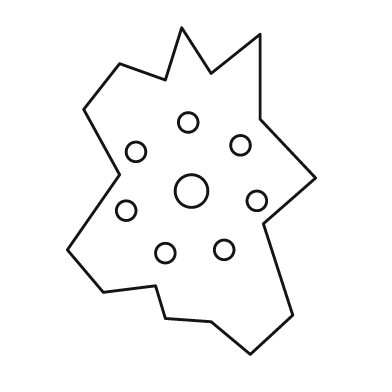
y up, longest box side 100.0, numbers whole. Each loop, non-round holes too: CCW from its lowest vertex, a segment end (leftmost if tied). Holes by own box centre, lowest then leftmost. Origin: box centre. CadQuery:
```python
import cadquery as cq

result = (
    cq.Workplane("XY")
    .moveTo(18.0, -50.0)
    .lineTo(31.0, -38.0)
    .lineTo(22.0, -10.0)
    .lineTo(38.0, 4.0)
    .lineTo(21.0, 22.0)
    .lineTo(21.0, 48.0)
    .lineTo(6.0, 36.0)
    .lineTo(-3.0, 50.0)
    .lineTo(-8.0, 34.0)
    .lineTo(-22.0, 39.0)
    .lineTo(-33.0, 25.0)
    .lineTo(-22.0, 5.0)
    .lineTo(-38.0, -18.0)
    .lineTo(-27.0, -31.0)
    .lineTo(-11.0, -29.0)
    .lineTo(-8.0, -39.0)
    .lineTo(6.0, -40.0)
    .close()
    .moveTo(-8.0, -19.0)
    .circle(3.0)
    .moveTo(10.0, -18.0)
    .circle(3.0)
    .moveTo(-20.0, -6.0)
    .circle(3.0)
    .moveTo(20.0, -3.0)
    .circle(3.0)
    .moveTo(0.0, 0.0)
    .circle(5.0)
    .moveTo(-17.0, 12.0)
    .circle(3.0)
    .moveTo(15.0, 14.0)
    .circle(3.0)
    .moveTo(-1.0, 21.0)
    .circle(3.0)
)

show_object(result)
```